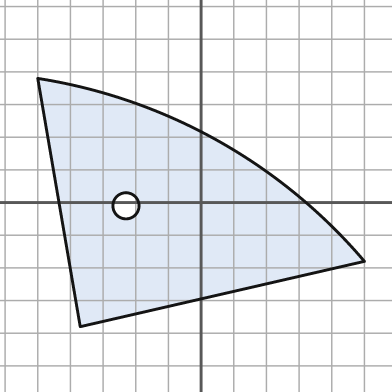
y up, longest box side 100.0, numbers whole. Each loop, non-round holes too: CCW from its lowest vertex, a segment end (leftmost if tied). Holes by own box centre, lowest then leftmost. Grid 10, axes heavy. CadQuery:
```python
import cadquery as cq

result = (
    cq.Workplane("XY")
    .moveTo(-37.0, -38.0)
    .lineTo(50.0, -18.0)
    .threePointArc((5.0, 19.0), (-50.0, 38.0))
    .close()
    .moveTo(-23.0, -1.0)
    .circle(4.0)
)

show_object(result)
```